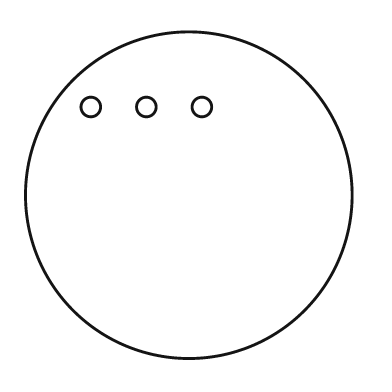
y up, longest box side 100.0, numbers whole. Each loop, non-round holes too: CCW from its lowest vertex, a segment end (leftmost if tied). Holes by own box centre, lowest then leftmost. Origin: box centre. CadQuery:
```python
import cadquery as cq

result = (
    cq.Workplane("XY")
    .moveTo(0.0, 0.0)
    .circle(50.0)
    .moveTo(-30.0, 27.0)
    .circle(3.0)
    .moveTo(-13.0, 27.0)
    .circle(3.0)
    .moveTo(4.0, 27.0)
    .circle(3.0)
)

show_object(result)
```